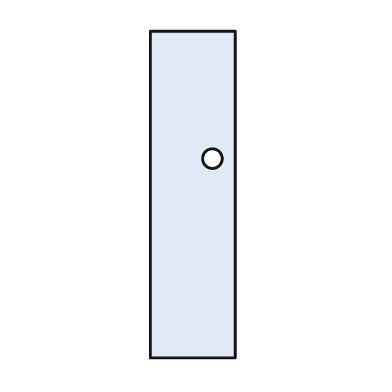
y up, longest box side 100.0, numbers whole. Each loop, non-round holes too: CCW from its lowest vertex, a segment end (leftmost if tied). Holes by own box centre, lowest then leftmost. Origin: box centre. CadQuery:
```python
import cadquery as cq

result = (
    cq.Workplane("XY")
    .moveTo(-13.0, -50.0)
    .lineTo(13.0, -50.0)
    .lineTo(13.0, 50.0)
    .lineTo(-13.0, 50.0)
    .close()
    .moveTo(6.0, 11.0)
    .circle(3.0)
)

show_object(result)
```